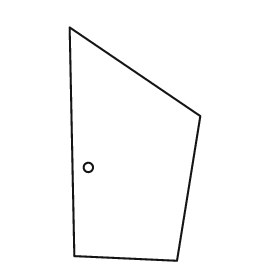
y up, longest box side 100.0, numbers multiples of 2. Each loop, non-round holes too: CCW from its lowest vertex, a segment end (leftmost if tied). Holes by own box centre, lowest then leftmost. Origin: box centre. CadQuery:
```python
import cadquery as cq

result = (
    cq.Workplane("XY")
    .moveTo(18.0, -50.0)
    .lineTo(28.0, 12.0)
    .lineTo(-28.0, 50.0)
    .lineTo(-26.0, -48.0)
    .close()
    .moveTo(-20.0, -10.0)
    .circle(2.0)
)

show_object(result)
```